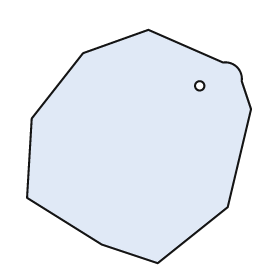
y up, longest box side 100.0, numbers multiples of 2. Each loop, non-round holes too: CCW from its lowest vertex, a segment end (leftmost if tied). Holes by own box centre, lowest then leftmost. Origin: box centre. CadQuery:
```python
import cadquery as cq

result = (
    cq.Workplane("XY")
    .moveTo(8.0, -50.0)
    .lineTo(38.0, -26.0)
    .lineTo(48.0, 16.0)
    .lineTo(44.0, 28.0)
    .threePointArc((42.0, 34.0), (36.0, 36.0))
    .lineTo(4.0, 50.0)
    .lineTo(-24.0, 40.0)
    .lineTo(-46.0, 12.0)
    .lineTo(-48.0, -22.0)
    .lineTo(-16.0, -42.0)
    .close()
    .moveTo(26.0, 26.0)
    .circle(2.0)
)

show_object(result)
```